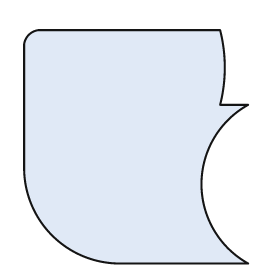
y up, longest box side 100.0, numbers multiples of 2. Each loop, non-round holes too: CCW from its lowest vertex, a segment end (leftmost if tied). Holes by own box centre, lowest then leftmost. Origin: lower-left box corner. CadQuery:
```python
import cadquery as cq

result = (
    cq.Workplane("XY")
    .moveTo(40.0, 0.0)
    .lineTo(96.0, 0.0)
    .threePointArc((76.0, 34.0), (96.0, 68.0))
    .lineTo(84.0, 68.0)
    .threePointArc((86.0, 84.0), (84.0, 100.0))
    .lineTo(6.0, 100.0)
    .threePointArc((2.0, 98.0), (0.0, 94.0))
    .lineTo(0.0, 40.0)
    .threePointArc((12.0, 12.0), (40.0, 0.0))
    .close()
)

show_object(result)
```